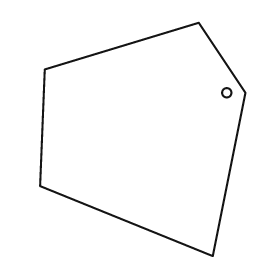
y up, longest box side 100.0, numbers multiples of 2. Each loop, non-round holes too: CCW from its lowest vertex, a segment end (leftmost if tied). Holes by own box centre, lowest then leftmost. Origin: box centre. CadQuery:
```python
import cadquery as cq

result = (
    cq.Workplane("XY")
    .moveTo(30.0, -50.0)
    .lineTo(44.0, 20.0)
    .lineTo(24.0, 50.0)
    .lineTo(-42.0, 30.0)
    .lineTo(-44.0, -20.0)
    .close()
    .moveTo(36.0, 20.0)
    .circle(2.0)
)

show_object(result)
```